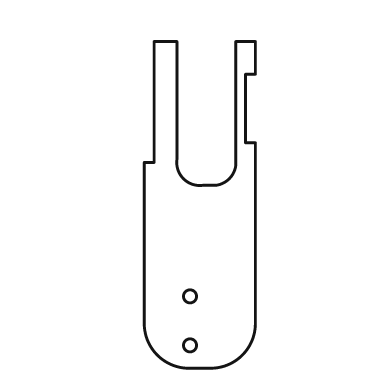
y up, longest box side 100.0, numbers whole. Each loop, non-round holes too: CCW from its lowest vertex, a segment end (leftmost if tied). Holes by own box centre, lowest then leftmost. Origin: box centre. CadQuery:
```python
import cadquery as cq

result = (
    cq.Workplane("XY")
    .moveTo(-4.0, -50.0)
    .lineTo(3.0, -50.0)
    .threePointArc((13.0, -46.0), (17.0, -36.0))
    .lineTo(17.0, 19.0)
    .lineTo(14.0, 19.0)
    .lineTo(14.0, 40.0)
    .lineTo(17.0, 40.0)
    .lineTo(17.0, 50.0)
    .lineTo(11.0, 50.0)
    .lineTo(11.0, 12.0)
    .threePointArc((9.0, 8.0), (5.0, 6.0))
    .lineTo(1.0, 6.0)
    .threePointArc((-5.0, 8.0), (-7.0, 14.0))
    .lineTo(-7.0, 50.0)
    .lineTo(-14.0, 50.0)
    .lineTo(-14.0, 13.0)
    .lineTo(-17.0, 13.0)
    .lineTo(-17.0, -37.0)
    .threePointArc((-13.0, -46.0), (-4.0, -50.0))
    .close()
    .moveTo(-3.0, -43.0)
    .circle(2.0)
    .moveTo(-3.0, -28.0)
    .circle(2.0)
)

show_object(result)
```